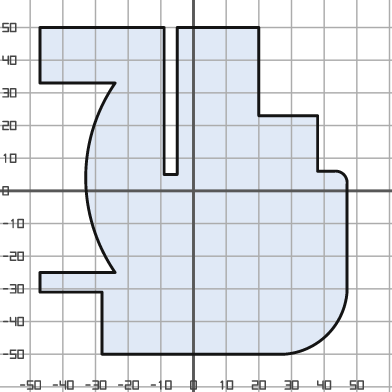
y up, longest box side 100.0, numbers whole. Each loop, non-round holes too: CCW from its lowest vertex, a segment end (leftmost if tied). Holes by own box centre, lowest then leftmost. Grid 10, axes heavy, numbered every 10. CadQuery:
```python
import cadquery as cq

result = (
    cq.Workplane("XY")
    .moveTo(-28.0, -50.0)
    .lineTo(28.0, -50.0)
    .threePointArc((41.0, -44.0), (47.0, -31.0))
    .lineTo(47.0, 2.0)
    .threePointArc((46.0, 5.0), (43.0, 6.0))
    .lineTo(38.0, 6.0)
    .lineTo(38.0, 23.0)
    .lineTo(20.0, 23.0)
    .lineTo(20.0, 50.0)
    .lineTo(-5.0, 50.0)
    .lineTo(-5.0, 5.0)
    .lineTo(-9.0, 5.0)
    .lineTo(-9.0, 50.0)
    .lineTo(-47.0, 50.0)
    .lineTo(-47.0, 33.0)
    .lineTo(-24.0, 33.0)
    .threePointArc((-33.0, 4.0), (-24.0, -25.0))
    .lineTo(-47.0, -25.0)
    .lineTo(-47.0, -31.0)
    .lineTo(-28.0, -31.0)
    .close()
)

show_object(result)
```